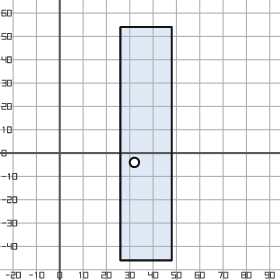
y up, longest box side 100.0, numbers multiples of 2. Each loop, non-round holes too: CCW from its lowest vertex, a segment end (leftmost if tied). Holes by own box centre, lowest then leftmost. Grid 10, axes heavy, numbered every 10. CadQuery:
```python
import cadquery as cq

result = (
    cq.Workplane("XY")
    .moveTo(26.0, -46.0)
    .lineTo(48.0, -46.0)
    .lineTo(48.0, 54.0)
    .lineTo(26.0, 54.0)
    .close()
    .moveTo(32.0, -4.0)
    .circle(2.0)
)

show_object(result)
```